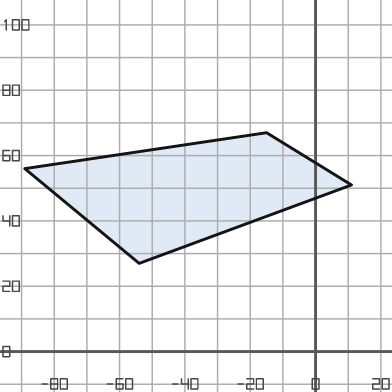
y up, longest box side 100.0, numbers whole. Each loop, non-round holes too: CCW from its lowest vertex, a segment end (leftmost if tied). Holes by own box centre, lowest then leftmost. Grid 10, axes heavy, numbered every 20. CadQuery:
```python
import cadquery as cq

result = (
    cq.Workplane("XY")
    .moveTo(-54.0, 27.0)
    .lineTo(11.0, 51.0)
    .lineTo(-15.0, 67.0)
    .lineTo(-89.0, 56.0)
    .close()
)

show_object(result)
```